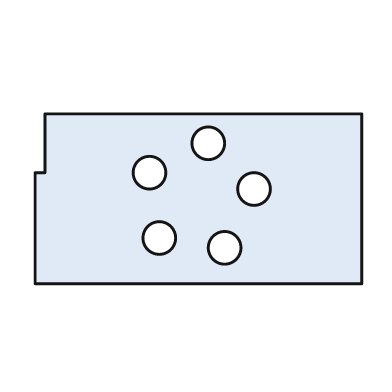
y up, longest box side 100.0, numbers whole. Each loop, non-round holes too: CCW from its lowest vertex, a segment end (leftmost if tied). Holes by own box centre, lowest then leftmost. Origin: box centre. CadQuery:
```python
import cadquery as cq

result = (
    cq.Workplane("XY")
    .moveTo(-50.0, -26.0)
    .lineTo(50.0, -26.0)
    .lineTo(50.0, 26.0)
    .lineTo(-47.0, 26.0)
    .lineTo(-47.0, 8.0)
    .lineTo(-50.0, 8.0)
    .close()
    .moveTo(8.0, -15.0)
    .circle(5.0)
    .moveTo(-12.0, -12.0)
    .circle(5.0)
    .moveTo(17.0, 3.0)
    .circle(5.0)
    .moveTo(-15.0, 8.0)
    .circle(5.0)
    .moveTo(3.0, 17.0)
    .circle(5.0)
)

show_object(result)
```